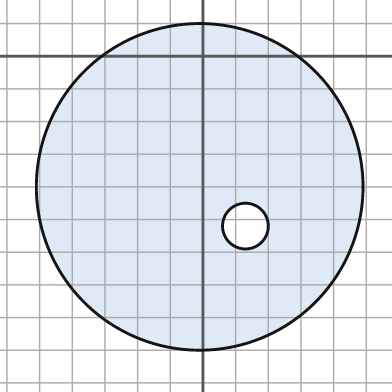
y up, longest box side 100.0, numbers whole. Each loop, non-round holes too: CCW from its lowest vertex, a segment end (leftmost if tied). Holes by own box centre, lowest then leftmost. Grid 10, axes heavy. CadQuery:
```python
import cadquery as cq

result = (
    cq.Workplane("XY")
    .moveTo(-1.0, -40.0)
    .circle(50.0)
    .moveTo(13.0, -52.0)
    .circle(7.0)
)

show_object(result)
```